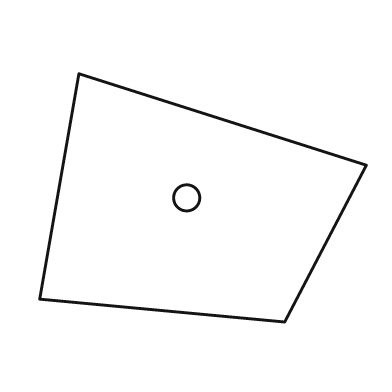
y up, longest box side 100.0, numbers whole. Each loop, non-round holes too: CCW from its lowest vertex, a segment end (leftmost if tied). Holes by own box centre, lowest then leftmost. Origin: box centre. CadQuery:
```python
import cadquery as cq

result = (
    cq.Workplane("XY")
    .moveTo(25.0, -38.0)
    .lineTo(50.0, 10.0)
    .lineTo(-38.0, 38.0)
    .lineTo(-50.0, -31.0)
    .close()
    .moveTo(-5.0, 0.0)
    .circle(4.0)
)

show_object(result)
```